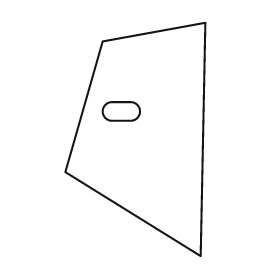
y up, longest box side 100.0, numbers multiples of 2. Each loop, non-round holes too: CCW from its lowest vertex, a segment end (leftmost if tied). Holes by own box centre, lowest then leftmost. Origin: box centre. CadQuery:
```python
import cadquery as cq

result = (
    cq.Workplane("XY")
    .moveTo(28.0, -50.0)
    .lineTo(30.0, 50.0)
    .lineTo(-14.0, 42.0)
    .lineTo(-30.0, -14.0)
    .close()
    .moveTo(-10.0, 8.0)
    .lineTo(-2.0, 8.0)
    .threePointArc((2.0, 12.0), (-2.0, 16.0))
    .lineTo(-10.0, 16.0)
    .threePointArc((-14.0, 12.0), (-10.0, 8.0))
    .close()
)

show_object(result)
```